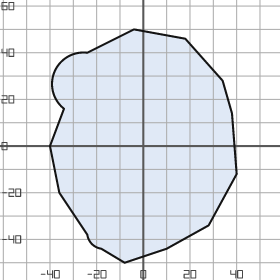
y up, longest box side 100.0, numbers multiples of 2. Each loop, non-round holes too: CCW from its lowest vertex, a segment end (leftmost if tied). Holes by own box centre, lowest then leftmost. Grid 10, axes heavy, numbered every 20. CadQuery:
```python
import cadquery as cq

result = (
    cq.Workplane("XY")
    .moveTo(-8.0, -50.0)
    .lineTo(10.0, -44.0)
    .lineTo(28.0, -34.0)
    .lineTo(40.0, -12.0)
    .lineTo(38.0, 14.0)
    .lineTo(34.0, 28.0)
    .lineTo(18.0, 46.0)
    .lineTo(-4.0, 50.0)
    .lineTo(-24.0, 40.0)
    .threePointArc((-38.0, 32.0), (-34.0, 16.0))
    .lineTo(-40.0, 0.0)
    .lineTo(-36.0, -20.0)
    .lineTo(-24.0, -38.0)
    .threePointArc((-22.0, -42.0), (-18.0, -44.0))
    .close()
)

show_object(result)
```